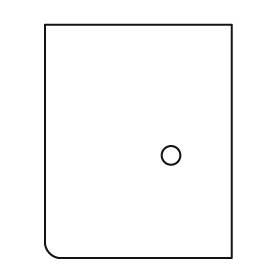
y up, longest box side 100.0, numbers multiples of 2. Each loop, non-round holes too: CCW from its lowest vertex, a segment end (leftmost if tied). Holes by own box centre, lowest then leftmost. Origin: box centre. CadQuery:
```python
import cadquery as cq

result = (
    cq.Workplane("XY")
    .moveTo(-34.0, -50.0)
    .lineTo(40.0, -50.0)
    .lineTo(40.0, 50.0)
    .lineTo(-40.0, 50.0)
    .lineTo(-40.0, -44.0)
    .threePointArc((-38.0, -48.0), (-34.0, -50.0))
    .close()
    .moveTo(14.0, -6.0)
    .circle(4.0)
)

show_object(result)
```